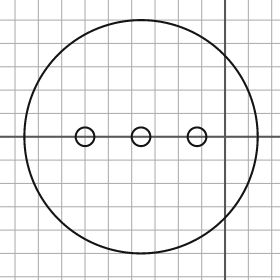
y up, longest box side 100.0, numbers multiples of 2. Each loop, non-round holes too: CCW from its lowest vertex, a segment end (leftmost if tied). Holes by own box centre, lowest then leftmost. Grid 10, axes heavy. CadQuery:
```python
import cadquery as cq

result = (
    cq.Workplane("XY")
    .moveTo(-36.0, 0.0)
    .circle(50.0)
    .moveTo(-60.0, 0.0)
    .circle(4.0)
    .moveTo(-36.0, 0.0)
    .circle(4.0)
    .moveTo(-12.0, 0.0)
    .circle(4.0)
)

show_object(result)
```